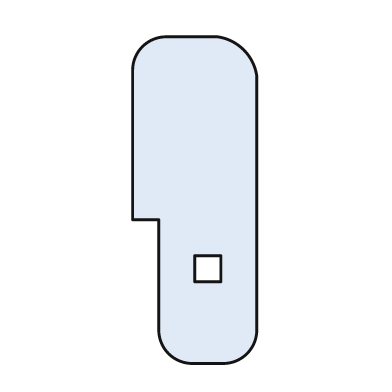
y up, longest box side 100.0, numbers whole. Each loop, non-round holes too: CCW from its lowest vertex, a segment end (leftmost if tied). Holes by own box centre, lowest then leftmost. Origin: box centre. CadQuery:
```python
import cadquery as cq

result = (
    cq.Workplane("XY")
    .moveTo(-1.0, -50.0)
    .lineTo(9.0, -50.0)
    .threePointArc((16.0, -47.0), (19.0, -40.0))
    .lineTo(19.0, 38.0)
    .threePointArc((15.0, 46.0), (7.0, 50.0))
    .lineTo(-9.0, 50.0)
    .threePointArc((-16.0, 47.0), (-19.0, 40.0))
    .lineTo(-19.0, -6.0)
    .lineTo(-11.0, -6.0)
    .lineTo(-11.0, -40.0)
    .threePointArc((-8.0, -47.0), (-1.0, -50.0))
    .close()
    .moveTo(0.0, -25.0)
    .lineTo(8.0, -25.0)
    .lineTo(8.0, -17.0)
    .lineTo(0.0, -17.0)
    .close()
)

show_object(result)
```